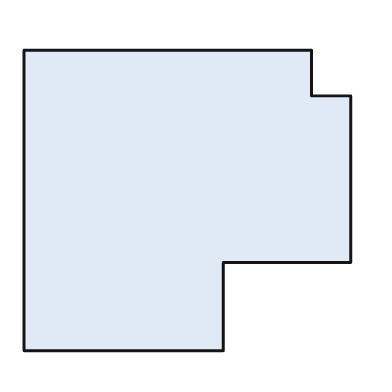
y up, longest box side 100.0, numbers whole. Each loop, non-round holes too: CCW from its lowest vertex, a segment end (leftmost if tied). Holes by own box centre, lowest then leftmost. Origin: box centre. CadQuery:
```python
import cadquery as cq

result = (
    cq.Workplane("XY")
    .moveTo(-50.0, -46.0)
    .lineTo(11.0, -46.0)
    .lineTo(11.0, -19.0)
    .lineTo(50.0, -19.0)
    .lineTo(50.0, 32.0)
    .lineTo(38.0, 32.0)
    .lineTo(38.0, 46.0)
    .lineTo(-50.0, 46.0)
    .close()
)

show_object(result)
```